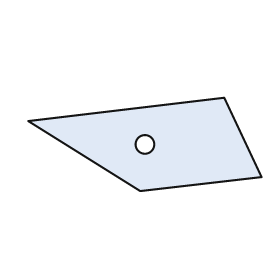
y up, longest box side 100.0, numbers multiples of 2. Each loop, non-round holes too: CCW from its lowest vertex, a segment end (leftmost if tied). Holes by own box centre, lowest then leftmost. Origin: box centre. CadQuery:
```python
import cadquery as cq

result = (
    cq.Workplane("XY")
    .moveTo(-2.0, -20.0)
    .lineTo(50.0, -14.0)
    .lineTo(34.0, 20.0)
    .lineTo(-50.0, 10.0)
    .close()
    .moveTo(0.0, 0.0)
    .circle(4.0)
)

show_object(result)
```